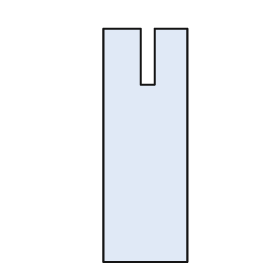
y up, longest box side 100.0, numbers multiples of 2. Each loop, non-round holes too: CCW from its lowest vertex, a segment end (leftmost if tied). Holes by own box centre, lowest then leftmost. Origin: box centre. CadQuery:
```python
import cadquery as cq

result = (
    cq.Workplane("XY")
    .moveTo(-18.0, -50.0)
    .lineTo(18.0, -50.0)
    .lineTo(18.0, 50.0)
    .lineTo(4.0, 50.0)
    .lineTo(4.0, 26.0)
    .lineTo(-2.0, 26.0)
    .lineTo(-2.0, 50.0)
    .lineTo(-18.0, 50.0)
    .close()
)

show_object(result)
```